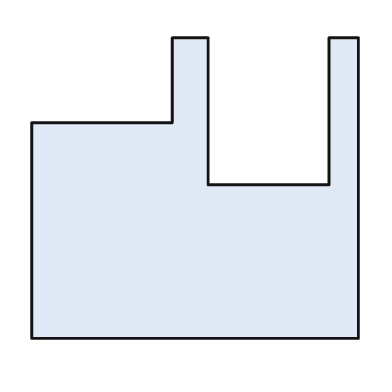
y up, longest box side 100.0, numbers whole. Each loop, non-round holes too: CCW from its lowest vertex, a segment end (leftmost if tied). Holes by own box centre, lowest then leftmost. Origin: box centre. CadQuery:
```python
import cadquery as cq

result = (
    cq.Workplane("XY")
    .moveTo(-50.0, -46.0)
    .lineTo(50.0, -46.0)
    .lineTo(50.0, 46.0)
    .lineTo(41.0, 46.0)
    .lineTo(41.0, 1.0)
    .lineTo(4.0, 1.0)
    .lineTo(4.0, 46.0)
    .lineTo(-7.0, 46.0)
    .lineTo(-7.0, 20.0)
    .lineTo(-50.0, 20.0)
    .close()
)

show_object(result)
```